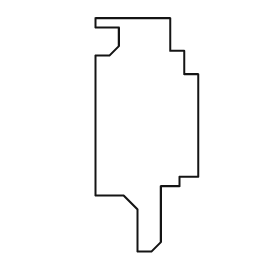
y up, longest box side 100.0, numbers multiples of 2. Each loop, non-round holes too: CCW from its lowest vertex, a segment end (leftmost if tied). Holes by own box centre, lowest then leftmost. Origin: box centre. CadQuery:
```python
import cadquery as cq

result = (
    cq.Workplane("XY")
    .moveTo(-4.0, -50.0)
    .lineTo(2.0, -50.0)
    .lineTo(6.0, -46.0)
    .lineTo(6.0, -22.0)
    .lineTo(14.0, -22.0)
    .lineTo(14.0, -18.0)
    .lineTo(22.0, -18.0)
    .lineTo(22.0, 26.0)
    .lineTo(16.0, 26.0)
    .lineTo(16.0, 36.0)
    .lineTo(10.0, 36.0)
    .lineTo(10.0, 50.0)
    .lineTo(-22.0, 50.0)
    .lineTo(-22.0, 46.0)
    .lineTo(-12.0, 46.0)
    .lineTo(-12.0, 38.0)
    .lineTo(-16.0, 34.0)
    .lineTo(-22.0, 34.0)
    .lineTo(-22.0, -26.0)
    .lineTo(-10.0, -26.0)
    .lineTo(-4.0, -32.0)
    .close()
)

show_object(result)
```